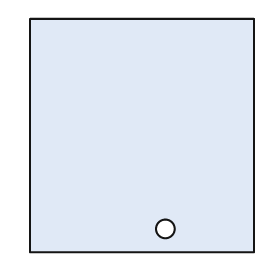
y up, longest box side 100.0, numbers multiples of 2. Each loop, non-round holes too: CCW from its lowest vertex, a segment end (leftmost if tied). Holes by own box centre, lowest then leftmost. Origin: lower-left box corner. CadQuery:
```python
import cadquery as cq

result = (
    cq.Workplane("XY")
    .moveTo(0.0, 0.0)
    .lineTo(96.0, 0.0)
    .lineTo(96.0, 100.0)
    .lineTo(0.0, 100.0)
    .close()
    .moveTo(58.0, 10.0)
    .circle(4.0)
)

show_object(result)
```